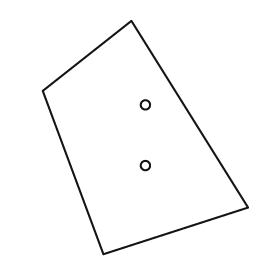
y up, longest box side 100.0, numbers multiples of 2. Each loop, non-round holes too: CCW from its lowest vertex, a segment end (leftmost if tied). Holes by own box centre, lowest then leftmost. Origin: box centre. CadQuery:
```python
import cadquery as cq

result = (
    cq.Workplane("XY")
    .moveTo(-18.0, -50.0)
    .lineTo(44.0, -30.0)
    .lineTo(-6.0, 50.0)
    .lineTo(-44.0, 20.0)
    .close()
    .moveTo(0.0, -12.0)
    .circle(2.0)
    .moveTo(0.0, 14.0)
    .circle(2.0)
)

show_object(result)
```